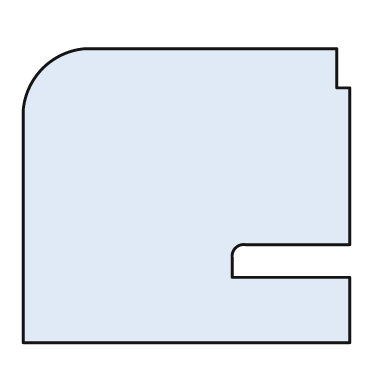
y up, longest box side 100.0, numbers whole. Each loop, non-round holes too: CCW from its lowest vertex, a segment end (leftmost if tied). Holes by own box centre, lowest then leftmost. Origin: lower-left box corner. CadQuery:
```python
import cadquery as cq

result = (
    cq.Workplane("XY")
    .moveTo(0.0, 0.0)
    .lineTo(100.0, 0.0)
    .lineTo(100.0, 20.0)
    .lineTo(64.0, 20.0)
    .lineTo(64.0, 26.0)
    .threePointArc((65.0, 29.0), (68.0, 30.0))
    .lineTo(100.0, 30.0)
    .lineTo(100.0, 78.0)
    .lineTo(96.0, 78.0)
    .lineTo(96.0, 90.0)
    .lineTo(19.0, 90.0)
    .threePointArc((6.0, 84.0), (0.0, 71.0))
    .close()
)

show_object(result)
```